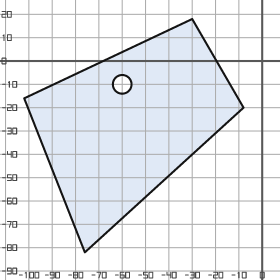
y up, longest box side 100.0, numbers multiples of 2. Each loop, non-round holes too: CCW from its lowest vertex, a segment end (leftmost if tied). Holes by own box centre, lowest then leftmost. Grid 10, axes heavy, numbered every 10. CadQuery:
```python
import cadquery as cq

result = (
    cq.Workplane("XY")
    .moveTo(-76.0, -82.0)
    .lineTo(-8.0, -20.0)
    .lineTo(-30.0, 18.0)
    .lineTo(-102.0, -16.0)
    .close()
    .moveTo(-60.0, -10.0)
    .circle(4.0)
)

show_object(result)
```